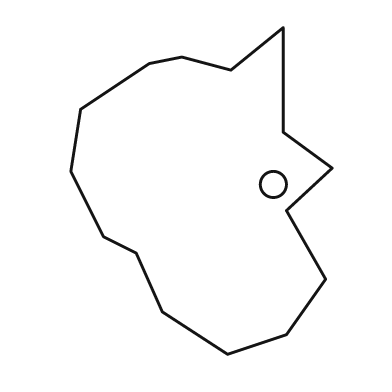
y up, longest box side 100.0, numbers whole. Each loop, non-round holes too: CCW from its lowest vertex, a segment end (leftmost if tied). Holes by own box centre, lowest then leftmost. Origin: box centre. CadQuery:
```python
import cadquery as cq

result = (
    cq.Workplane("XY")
    .moveTo(8.0, -50.0)
    .lineTo(26.0, -44.0)
    .lineTo(38.0, -27.0)
    .lineTo(26.0, -6.0)
    .lineTo(40.0, 7.0)
    .lineTo(25.0, 18.0)
    .lineTo(25.0, 50.0)
    .lineTo(9.0, 37.0)
    .lineTo(-6.0, 41.0)
    .lineTo(-16.0, 39.0)
    .lineTo(-37.0, 25.0)
    .lineTo(-40.0, 6.0)
    .lineTo(-30.0, -14.0)
    .lineTo(-20.0, -19.0)
    .lineTo(-12.0, -37.0)
    .close()
    .moveTo(22.0, 2.0)
    .circle(4.0)
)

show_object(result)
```